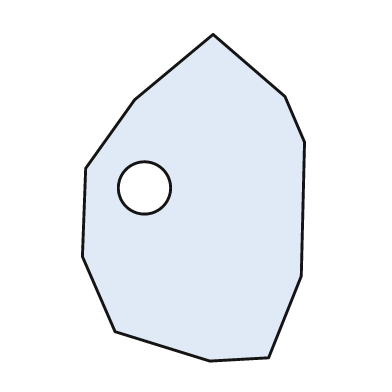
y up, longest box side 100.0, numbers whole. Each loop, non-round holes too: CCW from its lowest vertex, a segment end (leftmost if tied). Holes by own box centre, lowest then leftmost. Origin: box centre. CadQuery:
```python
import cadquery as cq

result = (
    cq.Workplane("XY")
    .moveTo(5.0, -50.0)
    .lineTo(23.0, -49.0)
    .lineTo(33.0, -24.0)
    .lineTo(34.0, 17.0)
    .lineTo(28.0, 31.0)
    .lineTo(6.0, 50.0)
    .lineTo(-18.0, 30.0)
    .lineTo(-33.0, 9.0)
    .lineTo(-34.0, -18.0)
    .lineTo(-24.0, -41.0)
    .close()
    .moveTo(-15.0, 3.0)
    .circle(8.0)
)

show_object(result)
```